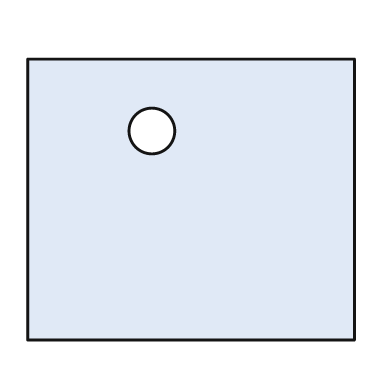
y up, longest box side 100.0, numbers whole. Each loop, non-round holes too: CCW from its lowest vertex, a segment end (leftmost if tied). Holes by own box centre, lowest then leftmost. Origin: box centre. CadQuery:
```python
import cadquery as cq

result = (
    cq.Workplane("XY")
    .moveTo(-50.0, -43.0)
    .lineTo(50.0, -43.0)
    .lineTo(50.0, 43.0)
    .lineTo(-50.0, 43.0)
    .close()
    .moveTo(-12.0, 21.0)
    .circle(7.0)
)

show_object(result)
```